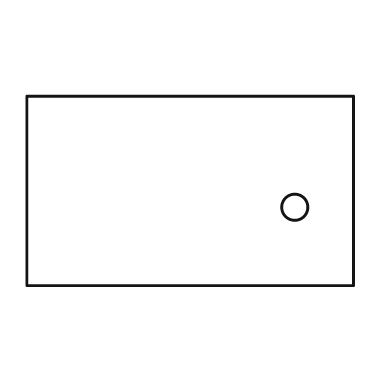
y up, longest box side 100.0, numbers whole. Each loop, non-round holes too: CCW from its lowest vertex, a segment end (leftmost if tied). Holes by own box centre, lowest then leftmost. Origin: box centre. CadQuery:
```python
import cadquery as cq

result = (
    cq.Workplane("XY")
    .moveTo(-50.0, -29.0)
    .lineTo(50.0, -29.0)
    .lineTo(50.0, 29.0)
    .lineTo(-50.0, 29.0)
    .close()
    .moveTo(32.0, -5.0)
    .circle(4.0)
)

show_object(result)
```